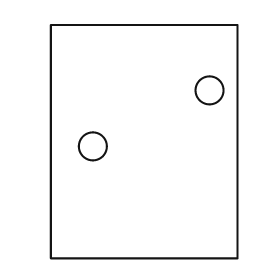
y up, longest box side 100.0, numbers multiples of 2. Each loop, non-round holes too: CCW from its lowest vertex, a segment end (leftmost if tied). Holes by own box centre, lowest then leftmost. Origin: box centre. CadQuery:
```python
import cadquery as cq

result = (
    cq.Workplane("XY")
    .moveTo(-40.0, -50.0)
    .lineTo(40.0, -50.0)
    .lineTo(40.0, 50.0)
    .lineTo(-40.0, 50.0)
    .close()
    .moveTo(-22.0, -2.0)
    .circle(6.0)
    .moveTo(28.0, 22.0)
    .circle(6.0)
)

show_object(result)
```